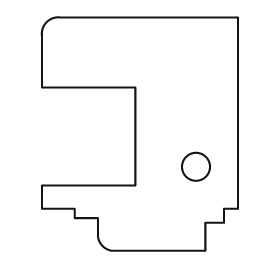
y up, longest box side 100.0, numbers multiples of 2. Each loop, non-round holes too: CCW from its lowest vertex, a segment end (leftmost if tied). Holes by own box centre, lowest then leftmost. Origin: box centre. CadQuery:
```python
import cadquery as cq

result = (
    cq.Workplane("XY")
    .moveTo(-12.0, -50.0)
    .lineTo(28.0, -50.0)
    .lineTo(28.0, -38.0)
    .lineTo(36.0, -38.0)
    .lineTo(36.0, -32.0)
    .lineTo(42.0, -32.0)
    .lineTo(42.0, 50.0)
    .lineTo(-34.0, 50.0)
    .threePointArc((-40.0, 48.0), (-42.0, 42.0))
    .lineTo(-42.0, 20.0)
    .lineTo(-2.0, 20.0)
    .lineTo(-2.0, -22.0)
    .lineTo(-42.0, -22.0)
    .lineTo(-42.0, -32.0)
    .lineTo(-28.0, -32.0)
    .lineTo(-28.0, -36.0)
    .lineTo(-18.0, -36.0)
    .lineTo(-18.0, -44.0)
    .threePointArc((-16.0, -48.0), (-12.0, -50.0))
    .close()
    .moveTo(24.0, -14.0)
    .circle(6.0)
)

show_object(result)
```